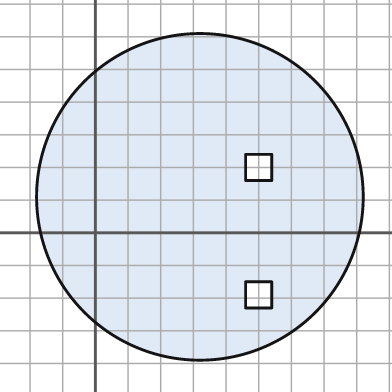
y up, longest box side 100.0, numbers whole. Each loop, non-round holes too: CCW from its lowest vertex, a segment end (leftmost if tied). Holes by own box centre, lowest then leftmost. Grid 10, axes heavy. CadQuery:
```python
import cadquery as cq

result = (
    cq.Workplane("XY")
    .moveTo(32.0, 11.0)
    .circle(50.0)
    .moveTo(46.0, -23.0)
    .lineTo(54.0, -23.0)
    .lineTo(54.0, -15.0)
    .lineTo(46.0, -15.0)
    .close()
    .moveTo(46.0, 16.0)
    .lineTo(54.0, 16.0)
    .lineTo(54.0, 24.0)
    .lineTo(46.0, 24.0)
    .close()
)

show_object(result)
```